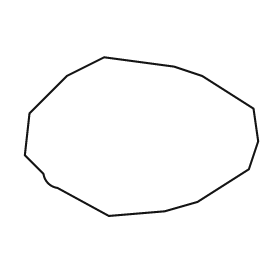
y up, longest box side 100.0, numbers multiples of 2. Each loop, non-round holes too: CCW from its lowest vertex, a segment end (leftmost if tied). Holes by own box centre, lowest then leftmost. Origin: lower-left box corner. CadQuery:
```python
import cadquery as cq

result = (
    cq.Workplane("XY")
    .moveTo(36.0, 0.0)
    .lineTo(60.0, 2.0)
    .lineTo(74.0, 6.0)
    .lineTo(96.0, 20.0)
    .lineTo(100.0, 32.0)
    .lineTo(98.0, 46.0)
    .lineTo(76.0, 60.0)
    .lineTo(64.0, 64.0)
    .lineTo(34.0, 68.0)
    .lineTo(18.0, 60.0)
    .lineTo(2.0, 44.0)
    .lineTo(0.0, 26.0)
    .lineTo(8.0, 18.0)
    .threePointArc((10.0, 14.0), (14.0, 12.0))
    .close()
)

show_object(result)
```